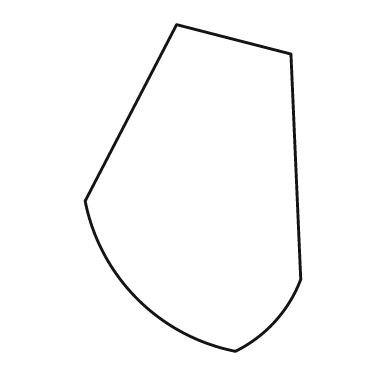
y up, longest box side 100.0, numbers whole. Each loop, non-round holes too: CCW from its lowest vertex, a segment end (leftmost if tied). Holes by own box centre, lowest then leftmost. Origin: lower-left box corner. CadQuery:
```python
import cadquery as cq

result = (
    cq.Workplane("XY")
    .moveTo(46.0, 0.0)
    .threePointArc((58.0, 9.0), (66.0, 22.0))
    .lineTo(63.0, 91.0)
    .lineTo(28.0, 100.0)
    .lineTo(0.0, 46.0)
    .threePointArc((16.0, 16.0), (46.0, 0.0))
    .close()
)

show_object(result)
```